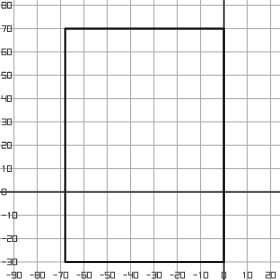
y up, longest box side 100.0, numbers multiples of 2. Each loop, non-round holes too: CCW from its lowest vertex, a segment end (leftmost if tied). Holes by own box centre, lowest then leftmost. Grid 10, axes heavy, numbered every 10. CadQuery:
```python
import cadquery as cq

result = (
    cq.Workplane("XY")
    .moveTo(-68.0, -30.0)
    .lineTo(0.0, -30.0)
    .lineTo(0.0, 70.0)
    .lineTo(-68.0, 70.0)
    .close()
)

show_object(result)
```